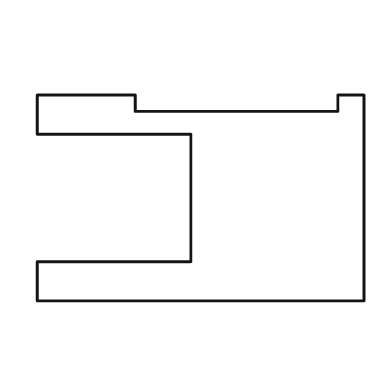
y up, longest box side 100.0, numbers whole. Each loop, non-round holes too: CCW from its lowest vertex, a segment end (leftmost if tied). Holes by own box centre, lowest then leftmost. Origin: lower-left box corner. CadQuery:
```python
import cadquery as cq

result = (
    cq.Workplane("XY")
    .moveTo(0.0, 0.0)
    .lineTo(100.0, 0.0)
    .lineTo(100.0, 63.0)
    .lineTo(92.0, 63.0)
    .lineTo(92.0, 58.0)
    .lineTo(30.0, 58.0)
    .lineTo(30.0, 63.0)
    .lineTo(0.0, 63.0)
    .lineTo(0.0, 51.0)
    .lineTo(47.0, 51.0)
    .lineTo(47.0, 12.0)
    .lineTo(0.0, 12.0)
    .close()
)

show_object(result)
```